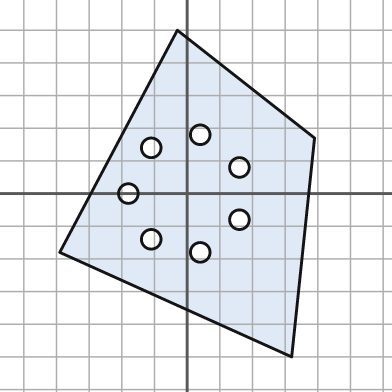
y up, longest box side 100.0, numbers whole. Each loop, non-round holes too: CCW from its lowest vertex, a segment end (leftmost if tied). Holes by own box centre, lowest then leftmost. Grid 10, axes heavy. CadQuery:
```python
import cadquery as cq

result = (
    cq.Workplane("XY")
    .moveTo(32.0, -50.0)
    .lineTo(39.0, 17.0)
    .lineTo(-3.0, 50.0)
    .lineTo(-39.0, -18.0)
    .close()
    .moveTo(4.0, -18.0)
    .circle(3.0)
    .moveTo(-11.0, -14.0)
    .circle(3.0)
    .moveTo(16.0, -8.0)
    .circle(3.0)
    .moveTo(-18.0, 0.0)
    .circle(3.0)
    .moveTo(16.0, 8.0)
    .circle(3.0)
    .moveTo(-11.0, 14.0)
    .circle(3.0)
    .moveTo(4.0, 18.0)
    .circle(3.0)
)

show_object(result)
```